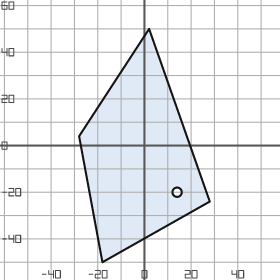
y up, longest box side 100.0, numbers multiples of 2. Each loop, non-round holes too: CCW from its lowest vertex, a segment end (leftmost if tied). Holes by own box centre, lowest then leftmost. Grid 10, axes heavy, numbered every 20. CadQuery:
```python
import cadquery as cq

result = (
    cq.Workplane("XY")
    .moveTo(-18.0, -50.0)
    .lineTo(28.0, -24.0)
    .lineTo(2.0, 50.0)
    .lineTo(-28.0, 4.0)
    .close()
    .moveTo(14.0, -20.0)
    .circle(2.0)
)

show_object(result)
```